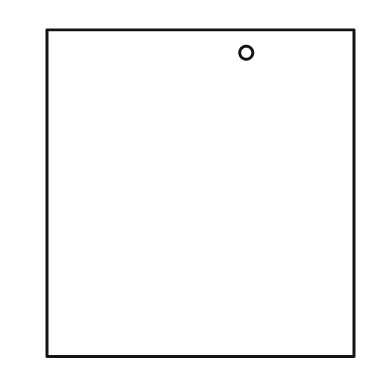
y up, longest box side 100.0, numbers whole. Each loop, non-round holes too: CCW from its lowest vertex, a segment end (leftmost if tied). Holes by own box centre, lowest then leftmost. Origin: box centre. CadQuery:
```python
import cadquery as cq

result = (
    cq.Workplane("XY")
    .moveTo(-47.0, -50.0)
    .lineTo(47.0, -50.0)
    .lineTo(47.0, 50.0)
    .lineTo(-47.0, 50.0)
    .close()
    .moveTo(14.0, 43.0)
    .circle(2.0)
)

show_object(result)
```